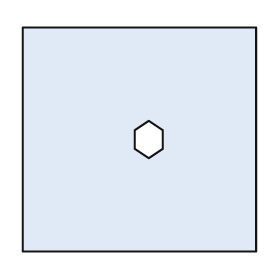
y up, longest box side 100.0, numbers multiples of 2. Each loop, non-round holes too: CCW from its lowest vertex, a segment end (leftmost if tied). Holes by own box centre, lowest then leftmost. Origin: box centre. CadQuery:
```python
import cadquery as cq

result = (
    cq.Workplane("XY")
    .moveTo(-50.0, -48.0)
    .lineTo(50.0, -48.0)
    .lineTo(50.0, 48.0)
    .lineTo(-50.0, 48.0)
    .close()
    .moveTo(4.0, -8.0)
    .lineTo(10.0, -4.0)
    .lineTo(10.0, 4.0)
    .lineTo(4.0, 8.0)
    .lineTo(-2.0, 4.0)
    .lineTo(-2.0, -4.0)
    .close()
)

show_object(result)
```